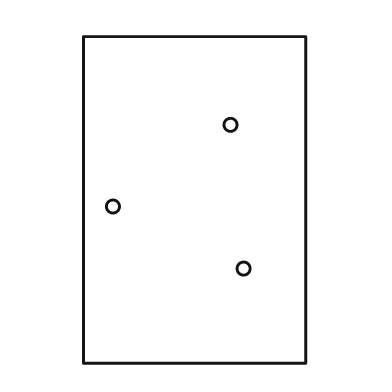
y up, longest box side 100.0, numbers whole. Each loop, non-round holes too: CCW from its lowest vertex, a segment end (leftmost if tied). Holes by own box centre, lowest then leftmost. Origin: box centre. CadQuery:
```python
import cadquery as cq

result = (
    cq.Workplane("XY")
    .moveTo(-34.0, -50.0)
    .lineTo(34.0, -50.0)
    .lineTo(34.0, 50.0)
    .lineTo(-34.0, 50.0)
    .close()
    .moveTo(15.0, -21.0)
    .circle(2.0)
    .moveTo(-25.0, -2.0)
    .circle(2.0)
    .moveTo(11.0, 23.0)
    .circle(2.0)
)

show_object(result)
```